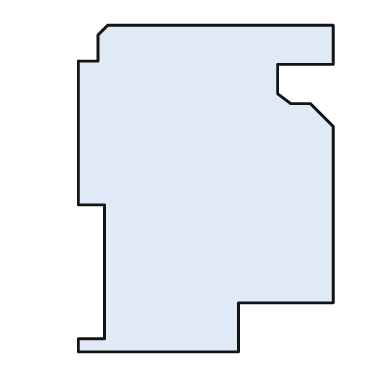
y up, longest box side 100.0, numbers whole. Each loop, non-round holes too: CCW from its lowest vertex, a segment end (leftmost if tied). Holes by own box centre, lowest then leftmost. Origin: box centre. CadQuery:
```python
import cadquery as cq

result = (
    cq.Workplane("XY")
    .moveTo(-39.0, -50.0)
    .lineTo(10.0, -50.0)
    .lineTo(10.0, -35.0)
    .lineTo(39.0, -35.0)
    .lineTo(39.0, 19.0)
    .lineTo(32.0, 26.0)
    .lineTo(26.0, 26.0)
    .lineTo(22.0, 29.0)
    .lineTo(22.0, 38.0)
    .lineTo(39.0, 38.0)
    .lineTo(39.0, 50.0)
    .lineTo(-30.0, 50.0)
    .lineTo(-33.0, 47.0)
    .lineTo(-33.0, 39.0)
    .lineTo(-39.0, 39.0)
    .lineTo(-39.0, -5.0)
    .lineTo(-31.0, -5.0)
    .lineTo(-31.0, -46.0)
    .lineTo(-39.0, -46.0)
    .close()
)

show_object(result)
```